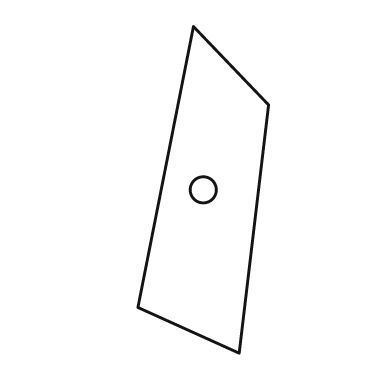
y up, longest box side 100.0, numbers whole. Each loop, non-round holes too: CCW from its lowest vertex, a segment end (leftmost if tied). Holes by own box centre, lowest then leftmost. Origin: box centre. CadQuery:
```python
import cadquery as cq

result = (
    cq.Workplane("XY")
    .moveTo(11.0, -50.0)
    .lineTo(20.0, 26.0)
    .lineTo(-3.0, 50.0)
    .lineTo(-20.0, -36.0)
    .close()
    .moveTo(0.0, 0.0)
    .circle(4.0)
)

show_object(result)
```